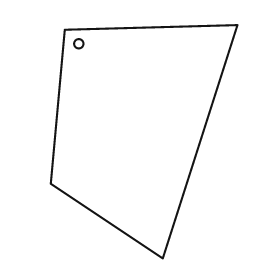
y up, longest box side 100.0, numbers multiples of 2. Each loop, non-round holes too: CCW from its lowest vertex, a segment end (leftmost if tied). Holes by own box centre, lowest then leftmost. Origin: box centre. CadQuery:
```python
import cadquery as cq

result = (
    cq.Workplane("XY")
    .moveTo(8.0, -50.0)
    .lineTo(40.0, 50.0)
    .lineTo(-34.0, 48.0)
    .lineTo(-40.0, -18.0)
    .close()
    .moveTo(-28.0, 42.0)
    .circle(2.0)
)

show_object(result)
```